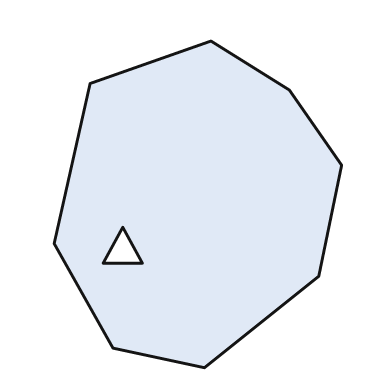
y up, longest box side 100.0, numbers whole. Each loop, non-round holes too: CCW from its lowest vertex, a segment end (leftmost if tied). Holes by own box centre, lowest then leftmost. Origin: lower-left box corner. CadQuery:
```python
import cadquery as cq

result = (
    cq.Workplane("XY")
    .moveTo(46.0, 0.0)
    .lineTo(81.0, 28.0)
    .lineTo(88.0, 62.0)
    .lineTo(72.0, 85.0)
    .lineTo(48.0, 100.0)
    .lineTo(11.0, 87.0)
    .lineTo(0.0, 38.0)
    .lineTo(18.0, 6.0)
    .close()
    .moveTo(15.0, 32.0)
    .lineTo(27.0, 32.0)
    .lineTo(21.0, 43.0)
    .close()
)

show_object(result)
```